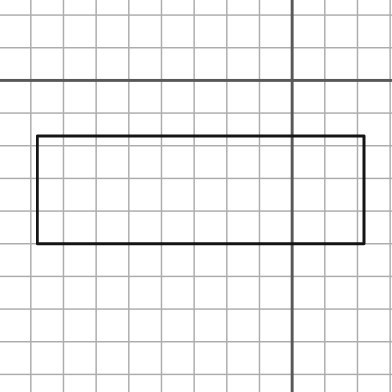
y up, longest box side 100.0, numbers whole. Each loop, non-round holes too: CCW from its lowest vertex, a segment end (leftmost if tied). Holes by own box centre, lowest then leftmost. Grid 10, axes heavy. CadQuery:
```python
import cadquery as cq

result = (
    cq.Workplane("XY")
    .moveTo(-78.0, -50.0)
    .lineTo(22.0, -50.0)
    .lineTo(22.0, -17.0)
    .lineTo(-78.0, -17.0)
    .close()
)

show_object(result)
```